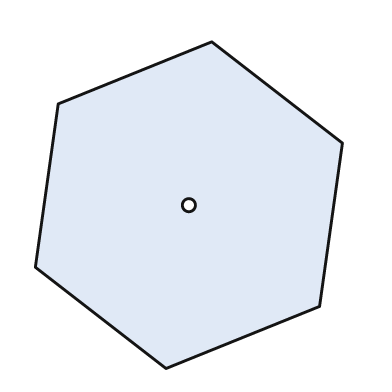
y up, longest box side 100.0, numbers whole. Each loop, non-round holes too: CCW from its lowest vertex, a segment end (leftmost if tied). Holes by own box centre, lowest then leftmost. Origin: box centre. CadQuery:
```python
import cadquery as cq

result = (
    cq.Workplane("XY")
    .moveTo(-7.0, -50.0)
    .lineTo(40.0, -31.0)
    .lineTo(47.0, 19.0)
    .lineTo(7.0, 50.0)
    .lineTo(-40.0, 31.0)
    .lineTo(-47.0, -19.0)
    .close()
    .moveTo(0.0, 0.0)
    .circle(2.0)
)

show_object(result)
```